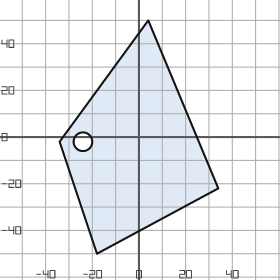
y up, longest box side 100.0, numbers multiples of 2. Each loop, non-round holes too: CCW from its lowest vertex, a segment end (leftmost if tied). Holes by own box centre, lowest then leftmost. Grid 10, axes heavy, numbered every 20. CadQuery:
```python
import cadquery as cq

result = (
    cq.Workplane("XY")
    .moveTo(-18.0, -50.0)
    .lineTo(34.0, -22.0)
    .lineTo(4.0, 50.0)
    .lineTo(-34.0, -2.0)
    .close()
    .moveTo(-24.0, -2.0)
    .circle(4.0)
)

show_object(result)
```